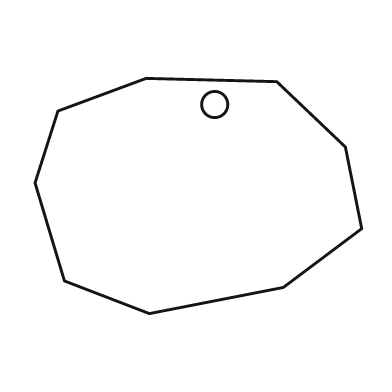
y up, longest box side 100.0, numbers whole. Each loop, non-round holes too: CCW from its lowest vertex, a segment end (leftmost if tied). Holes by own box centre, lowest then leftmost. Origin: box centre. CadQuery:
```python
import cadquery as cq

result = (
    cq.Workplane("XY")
    .moveTo(-15.0, -36.0)
    .lineTo(26.0, -28.0)
    .lineTo(50.0, -10.0)
    .lineTo(45.0, 15.0)
    .lineTo(24.0, 35.0)
    .lineTo(-16.0, 36.0)
    .lineTo(-43.0, 26.0)
    .lineTo(-50.0, 4.0)
    .lineTo(-41.0, -26.0)
    .close()
    .moveTo(5.0, 28.0)
    .circle(4.0)
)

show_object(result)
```